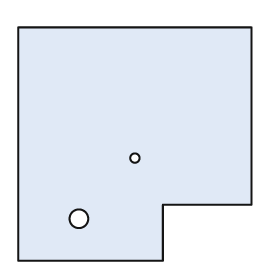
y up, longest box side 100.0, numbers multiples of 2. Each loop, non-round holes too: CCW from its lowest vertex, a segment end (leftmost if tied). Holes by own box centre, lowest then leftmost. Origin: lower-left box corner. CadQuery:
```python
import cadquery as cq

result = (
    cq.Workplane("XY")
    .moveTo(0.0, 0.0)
    .lineTo(62.0, 0.0)
    .lineTo(62.0, 24.0)
    .lineTo(100.0, 24.0)
    .lineTo(100.0, 100.0)
    .lineTo(0.0, 100.0)
    .close()
    .moveTo(26.0, 18.0)
    .circle(4.0)
    .moveTo(50.0, 44.0)
    .circle(2.0)
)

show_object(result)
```